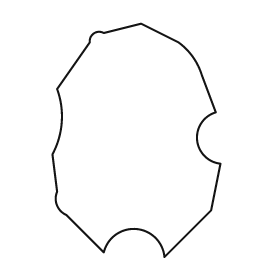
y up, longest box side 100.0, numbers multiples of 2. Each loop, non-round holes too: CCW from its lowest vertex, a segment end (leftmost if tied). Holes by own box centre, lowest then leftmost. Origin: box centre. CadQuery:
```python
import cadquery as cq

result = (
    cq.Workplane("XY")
    .moveTo(12.0, -50.0)
    .lineTo(32.0, -30.0)
    .lineTo(36.0, -10.0)
    .threePointArc((26.0, 0.0), (34.0, 12.0))
    .lineTo(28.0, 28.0)
    .threePointArc((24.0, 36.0), (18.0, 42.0))
    .lineTo(2.0, 50.0)
    .lineTo(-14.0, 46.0)
    .threePointArc((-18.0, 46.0), (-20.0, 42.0))
    .lineTo(-34.0, 22.0)
    .threePointArc((-32.0, 8.0), (-36.0, -6.0))
    .lineTo(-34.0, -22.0)
    .threePointArc((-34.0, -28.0), (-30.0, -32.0))
    .lineTo(-14.0, -48.0)
    .threePointArc((0.0, -38.0), (12.0, -50.0))
    .close()
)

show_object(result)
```